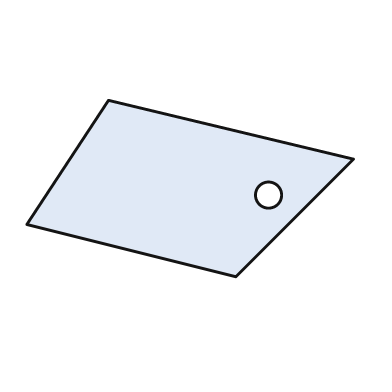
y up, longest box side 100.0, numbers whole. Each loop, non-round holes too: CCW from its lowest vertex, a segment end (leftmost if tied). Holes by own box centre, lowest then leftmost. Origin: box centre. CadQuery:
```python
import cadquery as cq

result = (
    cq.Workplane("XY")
    .moveTo(14.0, -27.0)
    .lineTo(50.0, 9.0)
    .lineTo(-25.0, 27.0)
    .lineTo(-50.0, -11.0)
    .close()
    .moveTo(24.0, -2.0)
    .circle(4.0)
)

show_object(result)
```